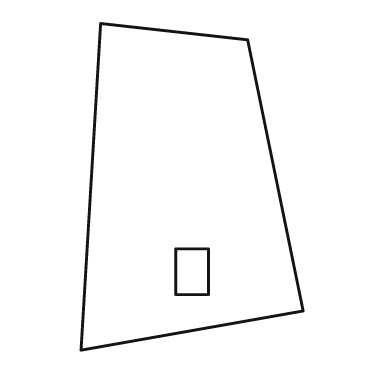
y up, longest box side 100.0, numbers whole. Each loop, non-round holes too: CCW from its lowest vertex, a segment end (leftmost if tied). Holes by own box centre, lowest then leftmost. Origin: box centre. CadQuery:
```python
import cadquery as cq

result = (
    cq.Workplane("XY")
    .moveTo(-34.0, -50.0)
    .lineTo(34.0, -38.0)
    .lineTo(17.0, 45.0)
    .lineTo(-28.0, 50.0)
    .close()
    .moveTo(-5.0, -33.0)
    .lineTo(5.0, -33.0)
    .lineTo(5.0, -19.0)
    .lineTo(-5.0, -19.0)
    .close()
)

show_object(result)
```